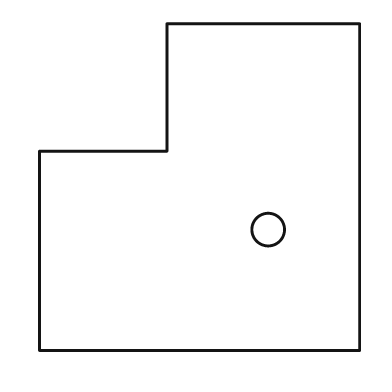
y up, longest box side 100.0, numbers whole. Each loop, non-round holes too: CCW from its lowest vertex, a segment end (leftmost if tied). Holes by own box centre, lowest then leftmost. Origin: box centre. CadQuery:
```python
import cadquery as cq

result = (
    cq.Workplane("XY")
    .moveTo(-49.0, -50.0)
    .lineTo(49.0, -50.0)
    .lineTo(49.0, 50.0)
    .lineTo(-10.0, 50.0)
    .lineTo(-10.0, 11.0)
    .lineTo(-49.0, 11.0)
    .close()
    .moveTo(21.0, -13.0)
    .circle(5.0)
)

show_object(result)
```